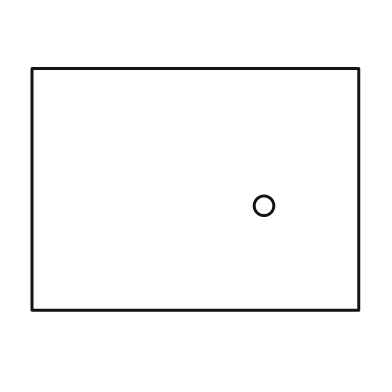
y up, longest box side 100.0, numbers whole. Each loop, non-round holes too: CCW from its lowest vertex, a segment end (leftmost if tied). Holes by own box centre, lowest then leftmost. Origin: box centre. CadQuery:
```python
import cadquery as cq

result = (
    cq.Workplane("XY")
    .moveTo(-50.0, -37.0)
    .lineTo(50.0, -37.0)
    .lineTo(50.0, 37.0)
    .lineTo(-50.0, 37.0)
    .close()
    .moveTo(21.0, -5.0)
    .circle(3.0)
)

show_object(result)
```